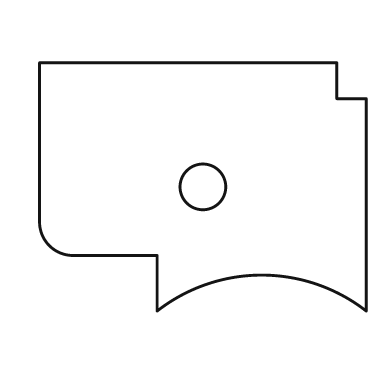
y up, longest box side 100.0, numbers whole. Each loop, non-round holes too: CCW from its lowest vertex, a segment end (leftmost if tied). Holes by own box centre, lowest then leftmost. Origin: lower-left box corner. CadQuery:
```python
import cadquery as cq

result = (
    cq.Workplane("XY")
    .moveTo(36.0, 0.0)
    .threePointArc((68.0, 11.0), (100.0, 0.0))
    .lineTo(100.0, 65.0)
    .lineTo(91.0, 65.0)
    .lineTo(91.0, 76.0)
    .lineTo(0.0, 76.0)
    .lineTo(0.0, 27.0)
    .threePointArc((3.0, 20.0), (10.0, 17.0))
    .lineTo(36.0, 17.0)
    .close()
    .moveTo(50.0, 38.0)
    .circle(7.0)
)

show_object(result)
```